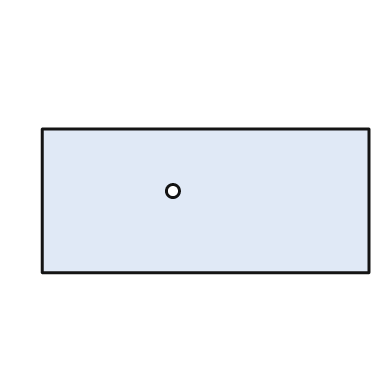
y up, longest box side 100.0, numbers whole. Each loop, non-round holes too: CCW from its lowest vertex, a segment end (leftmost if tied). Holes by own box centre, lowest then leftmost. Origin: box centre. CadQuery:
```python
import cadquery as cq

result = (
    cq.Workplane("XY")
    .moveTo(-50.0, -22.0)
    .lineTo(50.0, -22.0)
    .lineTo(50.0, 22.0)
    .lineTo(-50.0, 22.0)
    .close()
    .moveTo(-10.0, 3.0)
    .circle(2.0)
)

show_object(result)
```